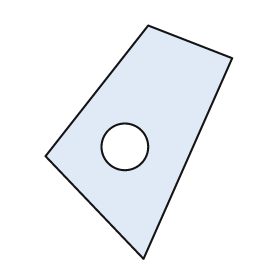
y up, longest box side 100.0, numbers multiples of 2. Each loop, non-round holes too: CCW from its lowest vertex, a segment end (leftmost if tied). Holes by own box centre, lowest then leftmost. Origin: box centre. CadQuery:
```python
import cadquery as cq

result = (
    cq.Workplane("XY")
    .moveTo(2.0, -50.0)
    .lineTo(40.0, 36.0)
    .lineTo(4.0, 50.0)
    .lineTo(-40.0, -6.0)
    .close()
    .moveTo(-6.0, -2.0)
    .circle(10.0)
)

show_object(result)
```